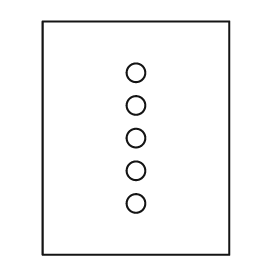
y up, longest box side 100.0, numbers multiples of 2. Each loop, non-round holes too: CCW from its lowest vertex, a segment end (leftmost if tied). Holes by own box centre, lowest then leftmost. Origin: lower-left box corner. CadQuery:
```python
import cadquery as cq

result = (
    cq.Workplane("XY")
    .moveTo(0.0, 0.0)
    .lineTo(80.0, 0.0)
    .lineTo(80.0, 100.0)
    .lineTo(0.0, 100.0)
    .close()
    .moveTo(40.0, 22.0)
    .circle(4.0)
    .moveTo(40.0, 36.0)
    .circle(4.0)
    .moveTo(40.0, 50.0)
    .circle(4.0)
    .moveTo(40.0, 64.0)
    .circle(4.0)
    .moveTo(40.0, 78.0)
    .circle(4.0)
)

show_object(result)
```